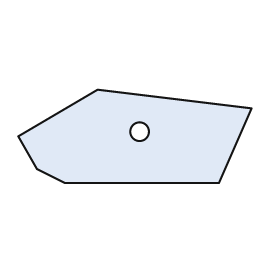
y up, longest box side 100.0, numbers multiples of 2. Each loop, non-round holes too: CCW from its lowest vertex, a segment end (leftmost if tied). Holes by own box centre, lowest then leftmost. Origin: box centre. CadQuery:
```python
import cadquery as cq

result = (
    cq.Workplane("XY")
    .moveTo(-30.0, -20.0)
    .lineTo(36.0, -20.0)
    .lineTo(50.0, 12.0)
    .lineTo(-16.0, 20.0)
    .lineTo(-50.0, 0.0)
    .lineTo(-42.0, -14.0)
    .close()
    .moveTo(2.0, 2.0)
    .circle(4.0)
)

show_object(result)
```